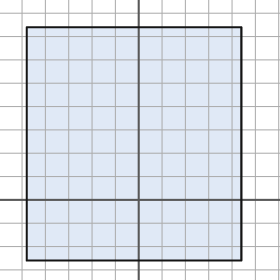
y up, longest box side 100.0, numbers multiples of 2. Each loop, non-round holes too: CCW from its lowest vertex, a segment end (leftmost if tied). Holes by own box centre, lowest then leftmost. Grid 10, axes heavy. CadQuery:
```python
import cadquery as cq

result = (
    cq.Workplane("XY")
    .moveTo(-48.0, -26.0)
    .lineTo(44.0, -26.0)
    .lineTo(44.0, 74.0)
    .lineTo(-48.0, 74.0)
    .close()
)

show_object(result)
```